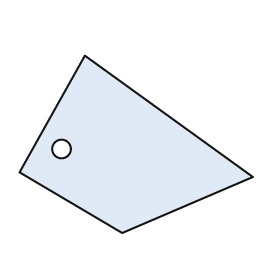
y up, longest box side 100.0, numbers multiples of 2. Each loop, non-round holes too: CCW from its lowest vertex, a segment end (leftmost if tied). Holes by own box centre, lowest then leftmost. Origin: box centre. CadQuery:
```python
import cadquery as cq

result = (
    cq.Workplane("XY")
    .moveTo(-6.0, -38.0)
    .lineTo(50.0, -14.0)
    .lineTo(-22.0, 38.0)
    .lineTo(-50.0, -12.0)
    .close()
    .moveTo(-32.0, -2.0)
    .circle(4.0)
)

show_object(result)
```